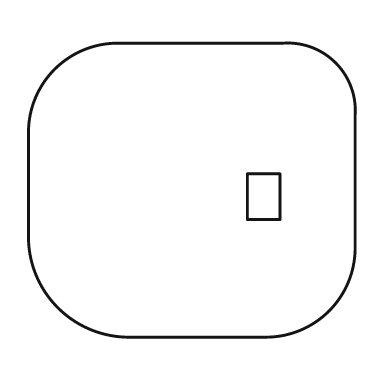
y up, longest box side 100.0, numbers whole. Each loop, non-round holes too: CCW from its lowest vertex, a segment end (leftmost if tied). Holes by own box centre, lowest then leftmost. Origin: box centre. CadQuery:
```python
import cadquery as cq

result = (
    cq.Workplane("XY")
    .moveTo(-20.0, -45.0)
    .lineTo(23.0, -45.0)
    .threePointArc((42.0, -37.0), (50.0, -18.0))
    .lineTo(50.0, 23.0)
    .threePointArc((44.0, 39.0), (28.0, 45.0))
    .lineTo(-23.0, 45.0)
    .threePointArc((-42.0, 37.0), (-50.0, 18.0))
    .lineTo(-50.0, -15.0)
    .threePointArc((-41.0, -36.0), (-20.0, -45.0))
    .close()
    .moveTo(17.0, -9.0)
    .lineTo(27.0, -9.0)
    .lineTo(27.0, 5.0)
    .lineTo(17.0, 5.0)
    .close()
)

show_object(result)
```